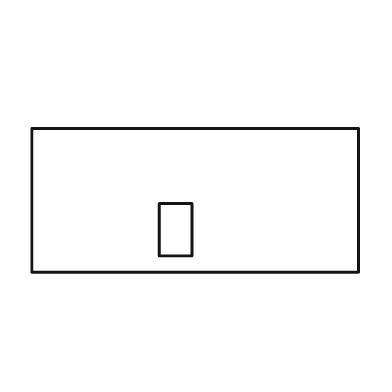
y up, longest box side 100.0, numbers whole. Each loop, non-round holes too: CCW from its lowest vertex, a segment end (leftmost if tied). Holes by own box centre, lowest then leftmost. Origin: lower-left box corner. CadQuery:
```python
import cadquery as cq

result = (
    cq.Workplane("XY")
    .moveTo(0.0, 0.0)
    .lineTo(100.0, 0.0)
    .lineTo(100.0, 44.0)
    .lineTo(0.0, 44.0)
    .close()
    .moveTo(39.0, 5.0)
    .lineTo(49.0, 5.0)
    .lineTo(49.0, 21.0)
    .lineTo(39.0, 21.0)
    .close()
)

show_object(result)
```